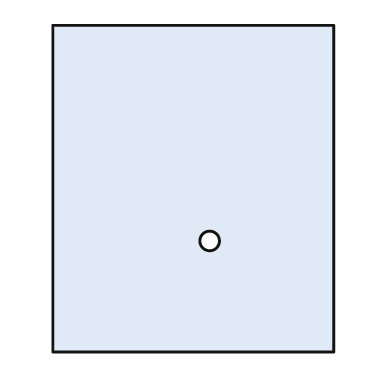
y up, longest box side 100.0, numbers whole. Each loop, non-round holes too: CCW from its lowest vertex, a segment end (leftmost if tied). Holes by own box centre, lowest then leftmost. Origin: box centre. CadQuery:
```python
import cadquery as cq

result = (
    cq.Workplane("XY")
    .moveTo(-43.0, -50.0)
    .lineTo(43.0, -50.0)
    .lineTo(43.0, 50.0)
    .lineTo(-43.0, 50.0)
    .close()
    .moveTo(5.0, -16.0)
    .circle(3.0)
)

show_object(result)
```